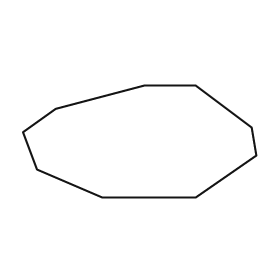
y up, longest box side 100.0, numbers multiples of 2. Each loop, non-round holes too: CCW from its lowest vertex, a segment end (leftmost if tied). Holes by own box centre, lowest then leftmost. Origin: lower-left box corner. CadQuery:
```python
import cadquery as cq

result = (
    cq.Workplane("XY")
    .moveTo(34.0, 0.0)
    .lineTo(74.0, 0.0)
    .lineTo(100.0, 18.0)
    .lineTo(98.0, 30.0)
    .lineTo(74.0, 48.0)
    .lineTo(52.0, 48.0)
    .lineTo(14.0, 38.0)
    .lineTo(0.0, 28.0)
    .lineTo(6.0, 12.0)
    .close()
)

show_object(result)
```